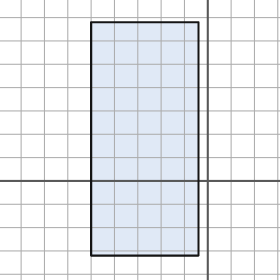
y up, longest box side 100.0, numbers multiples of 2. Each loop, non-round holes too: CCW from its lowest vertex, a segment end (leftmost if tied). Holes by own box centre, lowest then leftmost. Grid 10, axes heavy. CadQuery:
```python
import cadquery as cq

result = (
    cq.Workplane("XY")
    .moveTo(-50.0, -32.0)
    .lineTo(-4.0, -32.0)
    .lineTo(-4.0, 68.0)
    .lineTo(-50.0, 68.0)
    .close()
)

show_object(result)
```